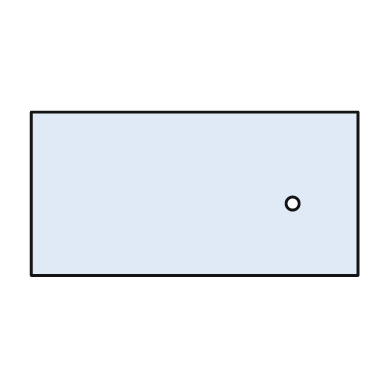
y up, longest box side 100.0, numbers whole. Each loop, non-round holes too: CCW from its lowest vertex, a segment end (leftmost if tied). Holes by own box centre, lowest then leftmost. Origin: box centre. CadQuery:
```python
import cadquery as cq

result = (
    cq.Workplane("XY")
    .moveTo(-50.0, -25.0)
    .lineTo(50.0, -25.0)
    .lineTo(50.0, 25.0)
    .lineTo(-50.0, 25.0)
    .close()
    .moveTo(30.0, -3.0)
    .circle(2.0)
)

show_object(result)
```